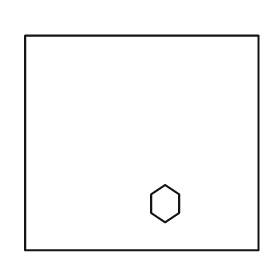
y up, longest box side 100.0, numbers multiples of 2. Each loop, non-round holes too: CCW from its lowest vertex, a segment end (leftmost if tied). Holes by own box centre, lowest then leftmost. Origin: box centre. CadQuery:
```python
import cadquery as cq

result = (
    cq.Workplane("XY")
    .moveTo(-50.0, -46.0)
    .lineTo(50.0, -46.0)
    .lineTo(50.0, 46.0)
    .lineTo(-50.0, 46.0)
    .close()
    .moveTo(10.0, -34.0)
    .lineTo(16.0, -30.0)
    .lineTo(16.0, -22.0)
    .lineTo(10.0, -18.0)
    .lineTo(4.0, -22.0)
    .lineTo(4.0, -30.0)
    .close()
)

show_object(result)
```